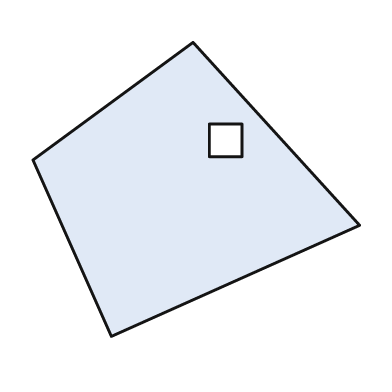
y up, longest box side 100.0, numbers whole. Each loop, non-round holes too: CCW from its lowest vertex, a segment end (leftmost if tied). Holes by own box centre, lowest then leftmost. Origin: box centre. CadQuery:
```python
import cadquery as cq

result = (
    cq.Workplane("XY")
    .moveTo(-26.0, -45.0)
    .lineTo(50.0, -11.0)
    .lineTo(-1.0, 45.0)
    .lineTo(-50.0, 9.0)
    .close()
    .moveTo(4.0, 10.0)
    .lineTo(14.0, 10.0)
    .lineTo(14.0, 20.0)
    .lineTo(4.0, 20.0)
    .close()
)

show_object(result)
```